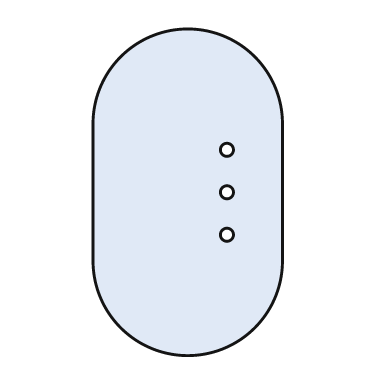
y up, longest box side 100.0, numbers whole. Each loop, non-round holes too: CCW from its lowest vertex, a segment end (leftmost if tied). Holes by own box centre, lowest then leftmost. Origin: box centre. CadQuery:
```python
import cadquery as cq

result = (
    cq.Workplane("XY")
    .moveTo(-29.0, -21.0)
    .threePointArc((0.0, -50.0), (29.0, -21.0))
    .lineTo(29.0, 21.0)
    .threePointArc((0.0, 50.0), (-29.0, 21.0))
    .close()
    .moveTo(12.0, -13.0)
    .circle(2.0)
    .moveTo(12.0, 0.0)
    .circle(2.0)
    .moveTo(12.0, 13.0)
    .circle(2.0)
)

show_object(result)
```